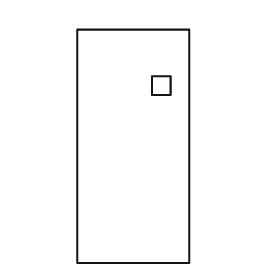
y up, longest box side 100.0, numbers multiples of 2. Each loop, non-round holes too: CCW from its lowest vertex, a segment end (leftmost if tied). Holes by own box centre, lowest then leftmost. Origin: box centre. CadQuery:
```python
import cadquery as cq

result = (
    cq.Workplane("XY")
    .moveTo(-24.0, -50.0)
    .lineTo(24.0, -50.0)
    .lineTo(24.0, 50.0)
    .lineTo(-24.0, 50.0)
    .close()
    .moveTo(8.0, 22.0)
    .lineTo(16.0, 22.0)
    .lineTo(16.0, 30.0)
    .lineTo(8.0, 30.0)
    .close()
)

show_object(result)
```